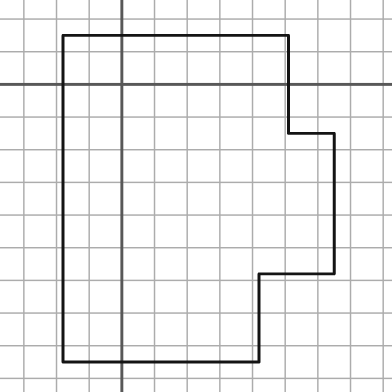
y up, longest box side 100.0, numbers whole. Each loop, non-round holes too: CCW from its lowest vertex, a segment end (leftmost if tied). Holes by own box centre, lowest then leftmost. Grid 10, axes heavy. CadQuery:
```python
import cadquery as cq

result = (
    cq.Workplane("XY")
    .moveTo(-18.0, -85.0)
    .lineTo(42.0, -85.0)
    .lineTo(42.0, -58.0)
    .lineTo(65.0, -58.0)
    .lineTo(65.0, -15.0)
    .lineTo(51.0, -15.0)
    .lineTo(51.0, 15.0)
    .lineTo(-18.0, 15.0)
    .close()
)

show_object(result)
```